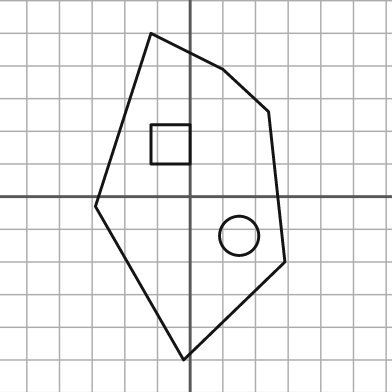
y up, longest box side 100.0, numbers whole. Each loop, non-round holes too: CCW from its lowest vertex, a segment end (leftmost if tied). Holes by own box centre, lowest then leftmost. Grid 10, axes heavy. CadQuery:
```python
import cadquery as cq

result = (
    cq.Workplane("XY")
    .moveTo(-2.0, -50.0)
    .lineTo(29.0, -20.0)
    .lineTo(24.0, 26.0)
    .lineTo(10.0, 39.0)
    .lineTo(-12.0, 50.0)
    .lineTo(-29.0, -3.0)
    .close()
    .moveTo(15.0, -12.0)
    .circle(6.0)
    .moveTo(-12.0, 10.0)
    .lineTo(0.0, 10.0)
    .lineTo(0.0, 22.0)
    .lineTo(-12.0, 22.0)
    .close()
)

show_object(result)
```